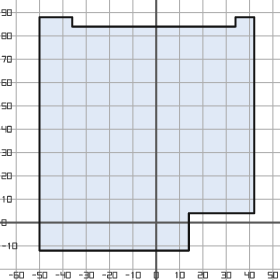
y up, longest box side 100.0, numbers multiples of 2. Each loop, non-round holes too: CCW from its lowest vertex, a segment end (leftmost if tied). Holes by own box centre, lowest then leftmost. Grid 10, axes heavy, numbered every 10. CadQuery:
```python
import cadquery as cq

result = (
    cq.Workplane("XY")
    .moveTo(-50.0, -12.0)
    .lineTo(14.0, -12.0)
    .lineTo(14.0, 4.0)
    .lineTo(42.0, 4.0)
    .lineTo(42.0, 88.0)
    .lineTo(34.0, 88.0)
    .lineTo(34.0, 84.0)
    .lineTo(-36.0, 84.0)
    .lineTo(-36.0, 88.0)
    .lineTo(-50.0, 88.0)
    .close()
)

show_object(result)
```